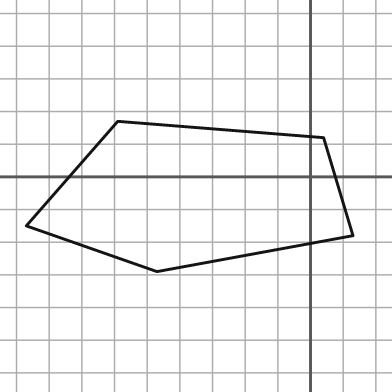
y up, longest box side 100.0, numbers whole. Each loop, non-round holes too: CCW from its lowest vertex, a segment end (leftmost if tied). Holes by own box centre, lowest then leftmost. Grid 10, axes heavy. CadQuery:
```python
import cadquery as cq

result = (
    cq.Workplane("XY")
    .moveTo(-47.0, -29.0)
    .lineTo(13.0, -18.0)
    .lineTo(4.0, 12.0)
    .lineTo(-59.0, 17.0)
    .lineTo(-87.0, -15.0)
    .close()
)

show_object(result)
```